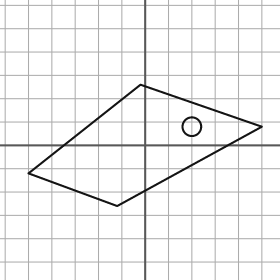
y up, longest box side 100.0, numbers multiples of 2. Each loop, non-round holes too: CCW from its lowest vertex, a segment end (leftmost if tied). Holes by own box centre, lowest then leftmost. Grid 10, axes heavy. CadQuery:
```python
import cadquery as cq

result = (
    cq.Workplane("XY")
    .moveTo(-12.0, -26.0)
    .lineTo(50.0, 8.0)
    .lineTo(-2.0, 26.0)
    .lineTo(-50.0, -12.0)
    .close()
    .moveTo(20.0, 8.0)
    .circle(4.0)
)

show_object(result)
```